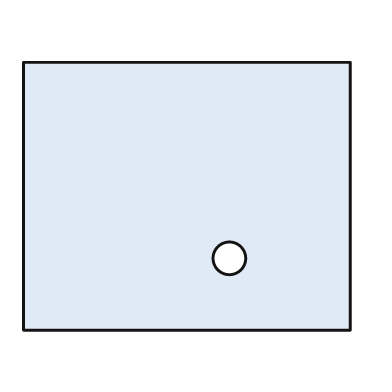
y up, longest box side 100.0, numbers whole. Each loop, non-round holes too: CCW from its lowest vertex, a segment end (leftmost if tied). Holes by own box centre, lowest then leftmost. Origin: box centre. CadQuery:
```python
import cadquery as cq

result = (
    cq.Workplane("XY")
    .moveTo(-50.0, -41.0)
    .lineTo(50.0, -41.0)
    .lineTo(50.0, 41.0)
    .lineTo(-50.0, 41.0)
    .close()
    .moveTo(13.0, -19.0)
    .circle(5.0)
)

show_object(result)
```